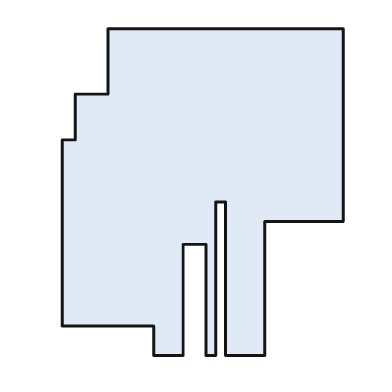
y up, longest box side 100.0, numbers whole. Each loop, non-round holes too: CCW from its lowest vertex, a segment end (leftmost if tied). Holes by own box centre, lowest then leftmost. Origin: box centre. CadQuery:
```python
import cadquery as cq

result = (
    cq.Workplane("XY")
    .moveTo(-15.0, -50.0)
    .lineTo(-6.0, -50.0)
    .lineTo(-6.0, -16.0)
    .lineTo(1.0, -16.0)
    .lineTo(1.0, -50.0)
    .lineTo(4.0, -50.0)
    .lineTo(4.0, -3.0)
    .lineTo(7.0, -3.0)
    .lineTo(7.0, -50.0)
    .lineTo(19.0, -50.0)
    .lineTo(19.0, -9.0)
    .lineTo(43.0, -9.0)
    .lineTo(43.0, 50.0)
    .lineTo(-29.0, 50.0)
    .lineTo(-29.0, 30.0)
    .lineTo(-39.0, 30.0)
    .lineTo(-39.0, 16.0)
    .lineTo(-43.0, 16.0)
    .lineTo(-43.0, -41.0)
    .lineTo(-15.0, -41.0)
    .close()
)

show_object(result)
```